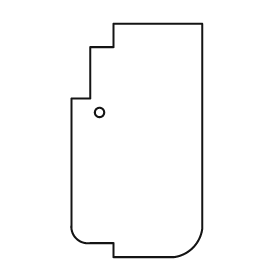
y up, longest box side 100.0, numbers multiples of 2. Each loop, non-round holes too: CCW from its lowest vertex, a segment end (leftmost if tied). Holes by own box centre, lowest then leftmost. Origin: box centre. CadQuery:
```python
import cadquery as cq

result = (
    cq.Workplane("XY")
    .moveTo(-10.0, -50.0)
    .lineTo(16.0, -50.0)
    .threePointArc((24.0, -46.0), (28.0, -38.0))
    .lineTo(28.0, 50.0)
    .lineTo(-10.0, 50.0)
    .lineTo(-10.0, 40.0)
    .lineTo(-20.0, 40.0)
    .lineTo(-20.0, 18.0)
    .lineTo(-28.0, 18.0)
    .lineTo(-28.0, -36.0)
    .threePointArc((-26.0, -42.0), (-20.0, -44.0))
    .lineTo(-10.0, -44.0)
    .close()
    .moveTo(-16.0, 12.0)
    .circle(2.0)
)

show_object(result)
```